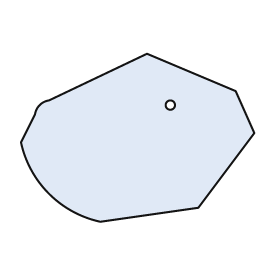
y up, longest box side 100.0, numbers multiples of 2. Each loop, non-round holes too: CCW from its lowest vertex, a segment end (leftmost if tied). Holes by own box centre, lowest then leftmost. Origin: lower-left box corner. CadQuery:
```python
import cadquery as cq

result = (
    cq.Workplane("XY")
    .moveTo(34.0, 0.0)
    .lineTo(76.0, 6.0)
    .lineTo(100.0, 38.0)
    .lineTo(92.0, 56.0)
    .lineTo(54.0, 72.0)
    .lineTo(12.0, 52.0)
    .threePointArc((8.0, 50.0), (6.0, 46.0))
    .lineTo(0.0, 34.0)
    .threePointArc((12.0, 12.0), (34.0, 0.0))
    .close()
    .moveTo(64.0, 50.0)
    .circle(2.0)
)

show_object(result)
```